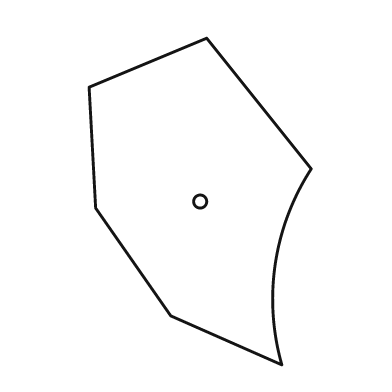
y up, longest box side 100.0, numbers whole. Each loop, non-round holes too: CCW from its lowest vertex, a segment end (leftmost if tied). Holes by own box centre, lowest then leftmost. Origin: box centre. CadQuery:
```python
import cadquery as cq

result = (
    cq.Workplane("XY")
    .moveTo(25.0, -50.0)
    .threePointArc((23.0, -19.0), (34.0, 10.0))
    .lineTo(2.0, 50.0)
    .lineTo(-34.0, 35.0)
    .lineTo(-32.0, -2.0)
    .lineTo(-9.0, -35.0)
    .close()
    .moveTo(0.0, 0.0)
    .circle(2.0)
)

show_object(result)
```